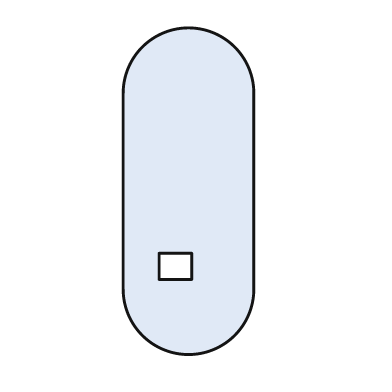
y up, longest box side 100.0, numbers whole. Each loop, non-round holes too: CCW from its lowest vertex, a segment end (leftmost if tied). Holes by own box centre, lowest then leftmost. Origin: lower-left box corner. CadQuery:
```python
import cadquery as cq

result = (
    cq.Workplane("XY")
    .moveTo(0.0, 20.0)
    .threePointArc((20.0, 0.0), (40.0, 20.0))
    .lineTo(40.0, 80.0)
    .threePointArc((20.0, 100.0), (0.0, 80.0))
    .close()
    .moveTo(11.0, 23.0)
    .lineTo(21.0, 23.0)
    .lineTo(21.0, 31.0)
    .lineTo(11.0, 31.0)
    .close()
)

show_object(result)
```